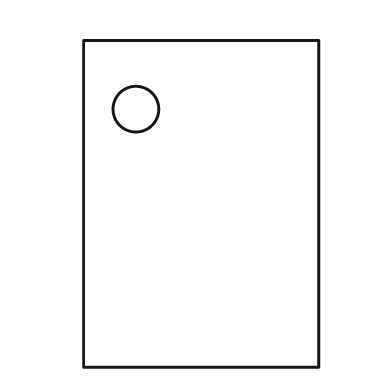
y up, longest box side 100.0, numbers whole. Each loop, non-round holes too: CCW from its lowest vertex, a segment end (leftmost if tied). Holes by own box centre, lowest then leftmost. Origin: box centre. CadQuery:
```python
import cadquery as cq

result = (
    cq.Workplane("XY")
    .moveTo(-36.0, -50.0)
    .lineTo(36.0, -50.0)
    .lineTo(36.0, 50.0)
    .lineTo(-36.0, 50.0)
    .close()
    .moveTo(-20.0, 29.0)
    .circle(7.0)
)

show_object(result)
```